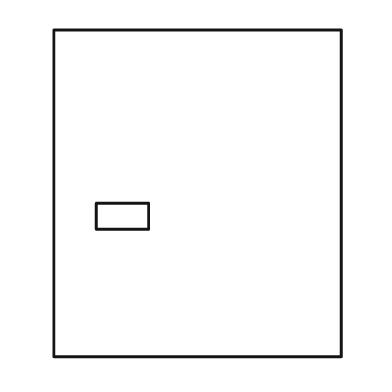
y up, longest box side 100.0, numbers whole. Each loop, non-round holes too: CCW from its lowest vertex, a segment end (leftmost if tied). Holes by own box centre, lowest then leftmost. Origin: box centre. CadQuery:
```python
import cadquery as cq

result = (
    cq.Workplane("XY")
    .moveTo(-44.0, -50.0)
    .lineTo(44.0, -50.0)
    .lineTo(44.0, 50.0)
    .lineTo(-44.0, 50.0)
    .close()
    .moveTo(-31.0, -11.0)
    .lineTo(-15.0, -11.0)
    .lineTo(-15.0, -3.0)
    .lineTo(-31.0, -3.0)
    .close()
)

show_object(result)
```